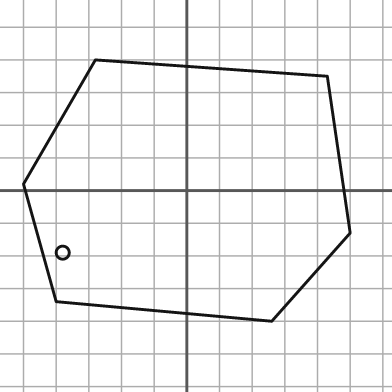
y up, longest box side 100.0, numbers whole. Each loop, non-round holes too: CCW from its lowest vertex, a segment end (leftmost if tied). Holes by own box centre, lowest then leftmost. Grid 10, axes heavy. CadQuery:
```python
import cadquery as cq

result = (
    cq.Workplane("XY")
    .moveTo(26.0, -40.0)
    .lineTo(50.0, -13.0)
    .lineTo(43.0, 35.0)
    .lineTo(-28.0, 40.0)
    .lineTo(-50.0, 2.0)
    .lineTo(-40.0, -34.0)
    .close()
    .moveTo(-38.0, -19.0)
    .circle(2.0)
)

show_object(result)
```